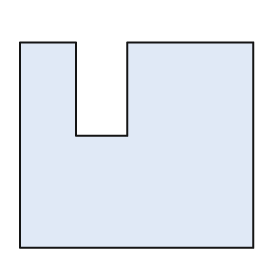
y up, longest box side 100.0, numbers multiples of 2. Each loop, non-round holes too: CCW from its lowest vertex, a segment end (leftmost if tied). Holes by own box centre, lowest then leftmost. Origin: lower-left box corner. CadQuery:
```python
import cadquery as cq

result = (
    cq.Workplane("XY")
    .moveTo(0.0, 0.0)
    .lineTo(100.0, 0.0)
    .lineTo(100.0, 88.0)
    .lineTo(46.0, 88.0)
    .lineTo(46.0, 48.0)
    .lineTo(24.0, 48.0)
    .lineTo(24.0, 88.0)
    .lineTo(0.0, 88.0)
    .close()
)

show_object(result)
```